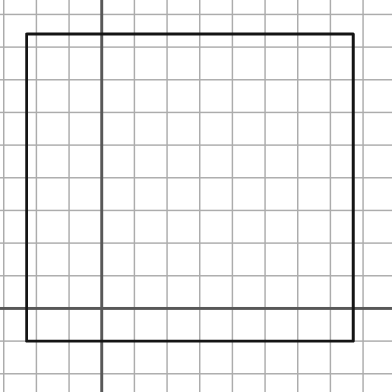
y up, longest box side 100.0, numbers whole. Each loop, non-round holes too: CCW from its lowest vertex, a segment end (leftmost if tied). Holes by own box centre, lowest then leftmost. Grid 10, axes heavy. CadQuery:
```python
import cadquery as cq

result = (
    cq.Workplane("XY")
    .moveTo(-23.0, -10.0)
    .lineTo(77.0, -10.0)
    .lineTo(77.0, 84.0)
    .lineTo(-23.0, 84.0)
    .close()
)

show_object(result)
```